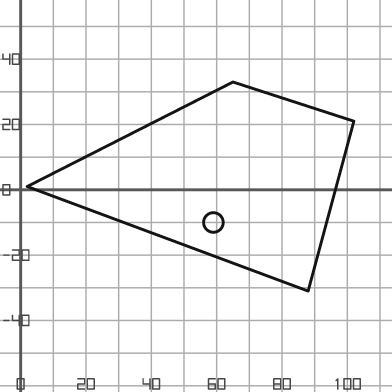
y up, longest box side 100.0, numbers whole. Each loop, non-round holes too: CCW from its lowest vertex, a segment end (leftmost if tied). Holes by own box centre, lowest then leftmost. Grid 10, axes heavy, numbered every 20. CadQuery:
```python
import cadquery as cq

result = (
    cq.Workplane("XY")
    .moveTo(88.0, -31.0)
    .lineTo(102.0, 21.0)
    .lineTo(65.0, 33.0)
    .lineTo(2.0, 1.0)
    .close()
    .moveTo(59.0, -10.0)
    .circle(3.0)
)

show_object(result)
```